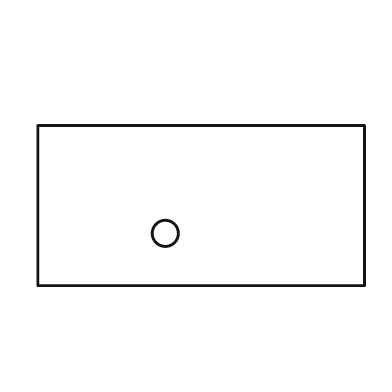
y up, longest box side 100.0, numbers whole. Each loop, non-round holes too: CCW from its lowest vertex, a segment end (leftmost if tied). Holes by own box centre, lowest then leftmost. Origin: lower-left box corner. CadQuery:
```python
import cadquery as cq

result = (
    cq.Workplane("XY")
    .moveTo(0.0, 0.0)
    .lineTo(100.0, 0.0)
    .lineTo(100.0, 49.0)
    .lineTo(0.0, 49.0)
    .close()
    .moveTo(39.0, 16.0)
    .circle(4.0)
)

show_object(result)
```